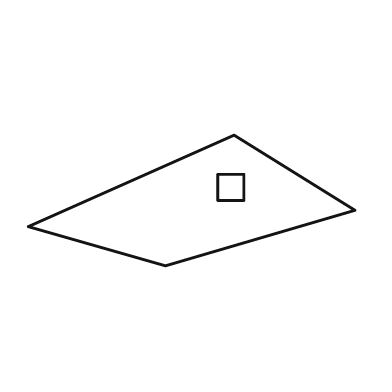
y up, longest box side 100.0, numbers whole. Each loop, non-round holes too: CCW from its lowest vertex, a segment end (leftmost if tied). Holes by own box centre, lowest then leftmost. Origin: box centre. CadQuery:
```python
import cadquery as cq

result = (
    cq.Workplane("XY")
    .moveTo(-8.0, -20.0)
    .lineTo(50.0, -3.0)
    .lineTo(13.0, 20.0)
    .lineTo(-50.0, -8.0)
    .close()
    .moveTo(8.0, 0.0)
    .lineTo(16.0, 0.0)
    .lineTo(16.0, 8.0)
    .lineTo(8.0, 8.0)
    .close()
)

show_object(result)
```